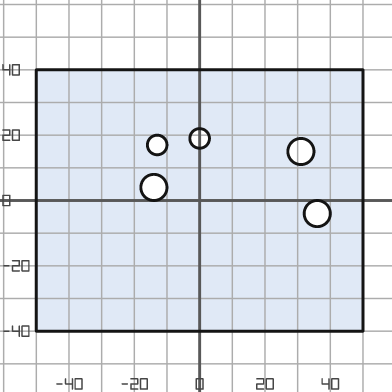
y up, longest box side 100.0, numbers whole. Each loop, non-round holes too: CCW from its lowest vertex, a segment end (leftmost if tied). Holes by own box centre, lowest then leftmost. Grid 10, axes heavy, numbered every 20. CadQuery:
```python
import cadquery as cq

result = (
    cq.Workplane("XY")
    .moveTo(-50.0, -40.0)
    .lineTo(50.0, -40.0)
    .lineTo(50.0, 40.0)
    .lineTo(-50.0, 40.0)
    .close()
    .moveTo(36.0, -4.0)
    .circle(4.0)
    .moveTo(-14.0, 4.0)
    .circle(4.0)
    .moveTo(31.0, 15.0)
    .circle(4.0)
    .moveTo(-13.0, 17.0)
    .circle(3.0)
    .moveTo(0.0, 19.0)
    .circle(3.0)
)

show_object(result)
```